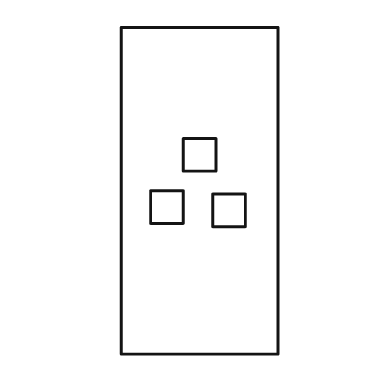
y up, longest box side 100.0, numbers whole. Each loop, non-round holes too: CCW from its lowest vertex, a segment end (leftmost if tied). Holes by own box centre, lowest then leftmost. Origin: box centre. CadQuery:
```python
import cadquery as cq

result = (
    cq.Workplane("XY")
    .moveTo(-24.0, -50.0)
    .lineTo(24.0, -50.0)
    .lineTo(24.0, 50.0)
    .lineTo(-24.0, 50.0)
    .close()
    .moveTo(4.0, -11.0)
    .lineTo(14.0, -11.0)
    .lineTo(14.0, -1.0)
    .lineTo(4.0, -1.0)
    .close()
    .moveTo(-15.0, -10.0)
    .lineTo(-5.0, -10.0)
    .lineTo(-5.0, 0.0)
    .lineTo(-15.0, 0.0)
    .close()
    .moveTo(-5.0, 6.0)
    .lineTo(5.0, 6.0)
    .lineTo(5.0, 16.0)
    .lineTo(-5.0, 16.0)
    .close()
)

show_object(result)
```